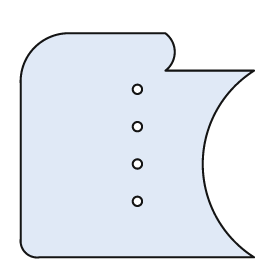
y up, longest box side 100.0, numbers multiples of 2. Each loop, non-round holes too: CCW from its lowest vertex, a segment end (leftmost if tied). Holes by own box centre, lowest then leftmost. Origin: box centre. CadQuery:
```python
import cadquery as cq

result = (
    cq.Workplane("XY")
    .moveTo(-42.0, -48.0)
    .lineTo(50.0, -48.0)
    .threePointArc((28.0, -8.0), (50.0, 32.0))
    .lineTo(12.0, 32.0)
    .threePointArc((16.0, 40.0), (12.0, 48.0))
    .lineTo(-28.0, 48.0)
    .threePointArc((-44.0, 42.0), (-50.0, 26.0))
    .lineTo(-50.0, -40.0)
    .threePointArc((-48.0, -46.0), (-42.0, -48.0))
    .close()
    .moveTo(0.0, -24.0)
    .circle(2.0)
    .moveTo(0.0, -8.0)
    .circle(2.0)
    .moveTo(0.0, 8.0)
    .circle(2.0)
    .moveTo(0.0, 24.0)
    .circle(2.0)
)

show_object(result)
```